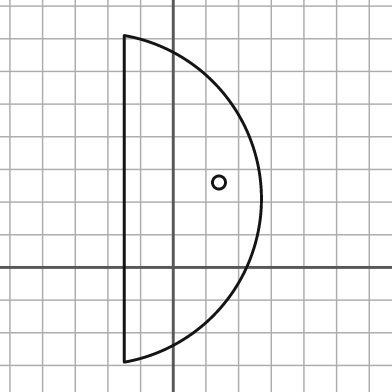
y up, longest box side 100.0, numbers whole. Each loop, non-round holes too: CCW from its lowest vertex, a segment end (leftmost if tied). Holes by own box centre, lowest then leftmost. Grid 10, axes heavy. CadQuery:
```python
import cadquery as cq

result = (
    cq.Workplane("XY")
    .moveTo(-15.0, -29.0)
    .threePointArc((27.0, 21.0), (-15.0, 71.0))
    .close()
    .moveTo(14.0, 26.0)
    .circle(2.0)
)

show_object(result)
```